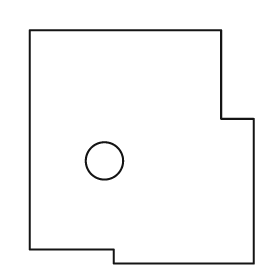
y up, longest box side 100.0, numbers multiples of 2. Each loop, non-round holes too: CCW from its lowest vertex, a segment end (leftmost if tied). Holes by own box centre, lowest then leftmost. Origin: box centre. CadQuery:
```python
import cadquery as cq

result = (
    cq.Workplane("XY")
    .moveTo(-12.0, -50.0)
    .lineTo(48.0, -50.0)
    .lineTo(48.0, 12.0)
    .lineTo(34.0, 12.0)
    .lineTo(34.0, 50.0)
    .lineTo(-48.0, 50.0)
    .lineTo(-48.0, -44.0)
    .lineTo(-12.0, -44.0)
    .close()
    .moveTo(-16.0, -6.0)
    .circle(8.0)
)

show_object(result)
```